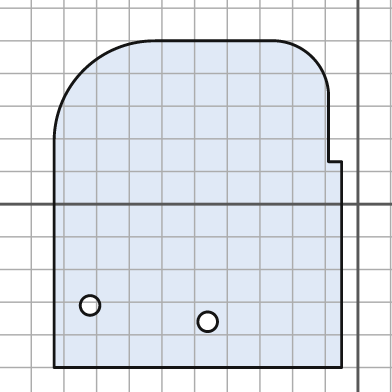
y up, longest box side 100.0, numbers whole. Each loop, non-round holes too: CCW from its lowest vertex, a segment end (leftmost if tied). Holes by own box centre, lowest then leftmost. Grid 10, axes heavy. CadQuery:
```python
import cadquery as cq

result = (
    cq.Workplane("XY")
    .moveTo(-93.0, -50.0)
    .lineTo(-5.0, -50.0)
    .lineTo(-5.0, 13.0)
    .lineTo(-9.0, 13.0)
    .lineTo(-9.0, 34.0)
    .threePointArc((-14.0, 45.0), (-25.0, 50.0))
    .lineTo(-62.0, 50.0)
    .threePointArc((-84.0, 41.0), (-93.0, 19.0))
    .close()
    .moveTo(-46.0, -36.0)
    .circle(3.0)
    .moveTo(-82.0, -31.0)
    .circle(3.0)
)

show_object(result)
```